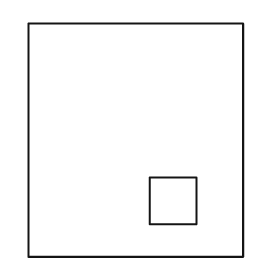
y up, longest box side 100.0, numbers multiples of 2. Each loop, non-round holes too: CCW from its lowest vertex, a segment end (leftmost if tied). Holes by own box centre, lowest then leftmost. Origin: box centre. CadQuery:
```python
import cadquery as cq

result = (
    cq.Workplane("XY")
    .moveTo(-46.0, -50.0)
    .lineTo(46.0, -50.0)
    .lineTo(46.0, 50.0)
    .lineTo(-46.0, 50.0)
    .close()
    .moveTo(6.0, -36.0)
    .lineTo(26.0, -36.0)
    .lineTo(26.0, -16.0)
    .lineTo(6.0, -16.0)
    .close()
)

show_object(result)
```